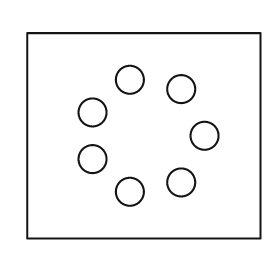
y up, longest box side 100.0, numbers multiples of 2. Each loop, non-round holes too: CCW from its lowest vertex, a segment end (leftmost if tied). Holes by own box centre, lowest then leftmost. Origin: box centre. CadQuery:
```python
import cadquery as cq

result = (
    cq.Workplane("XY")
    .moveTo(-50.0, -44.0)
    .lineTo(50.0, -44.0)
    .lineTo(50.0, 44.0)
    .lineTo(-50.0, 44.0)
    .close()
    .moveTo(-6.0, -24.0)
    .circle(6.0)
    .moveTo(16.0, -20.0)
    .circle(6.0)
    .moveTo(-22.0, -10.0)
    .circle(6.0)
    .moveTo(26.0, 0.0)
    .circle(6.0)
    .moveTo(-22.0, 10.0)
    .circle(6.0)
    .moveTo(16.0, 20.0)
    .circle(6.0)
    .moveTo(-6.0, 24.0)
    .circle(6.0)
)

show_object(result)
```